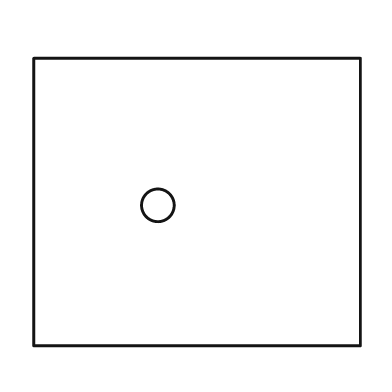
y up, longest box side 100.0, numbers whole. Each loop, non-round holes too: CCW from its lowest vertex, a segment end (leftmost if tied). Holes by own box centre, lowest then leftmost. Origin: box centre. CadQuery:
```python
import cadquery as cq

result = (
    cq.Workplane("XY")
    .moveTo(-50.0, -44.0)
    .lineTo(50.0, -44.0)
    .lineTo(50.0, 44.0)
    .lineTo(-50.0, 44.0)
    .close()
    .moveTo(-12.0, -1.0)
    .circle(5.0)
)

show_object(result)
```